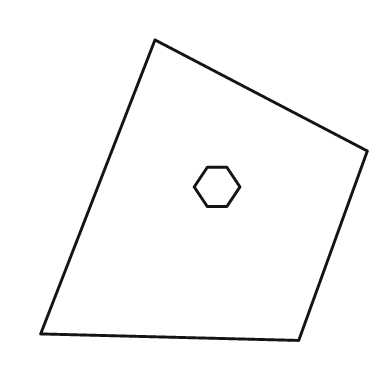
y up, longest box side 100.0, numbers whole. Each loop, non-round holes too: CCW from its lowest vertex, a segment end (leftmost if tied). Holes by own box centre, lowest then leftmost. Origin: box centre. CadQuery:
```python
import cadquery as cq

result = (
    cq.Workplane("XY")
    .moveTo(29.0, -46.0)
    .lineTo(50.0, 12.0)
    .lineTo(-15.0, 46.0)
    .lineTo(-50.0, -44.0)
    .close()
    .moveTo(1.0, -5.0)
    .lineTo(7.0, -5.0)
    .lineTo(11.0, 1.0)
    .lineTo(7.0, 7.0)
    .lineTo(1.0, 7.0)
    .lineTo(-3.0, 1.0)
    .close()
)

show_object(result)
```